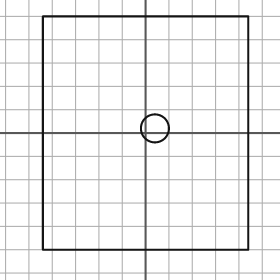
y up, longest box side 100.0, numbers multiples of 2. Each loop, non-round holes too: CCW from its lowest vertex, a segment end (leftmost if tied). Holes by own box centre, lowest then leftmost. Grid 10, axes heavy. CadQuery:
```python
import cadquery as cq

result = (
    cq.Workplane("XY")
    .moveTo(-44.0, -50.0)
    .lineTo(44.0, -50.0)
    .lineTo(44.0, 50.0)
    .lineTo(-44.0, 50.0)
    .close()
    .moveTo(4.0, 2.0)
    .circle(6.0)
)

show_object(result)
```